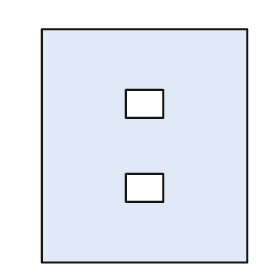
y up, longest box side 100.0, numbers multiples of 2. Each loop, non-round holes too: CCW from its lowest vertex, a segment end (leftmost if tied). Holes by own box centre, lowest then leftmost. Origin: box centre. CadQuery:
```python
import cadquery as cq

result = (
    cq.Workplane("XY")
    .moveTo(-44.0, -50.0)
    .lineTo(44.0, -50.0)
    .lineTo(44.0, 50.0)
    .lineTo(-44.0, 50.0)
    .close()
    .moveTo(-8.0, -24.0)
    .lineTo(8.0, -24.0)
    .lineTo(8.0, -12.0)
    .lineTo(-8.0, -12.0)
    .close()
    .moveTo(-8.0, 12.0)
    .lineTo(8.0, 12.0)
    .lineTo(8.0, 24.0)
    .lineTo(-8.0, 24.0)
    .close()
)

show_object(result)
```